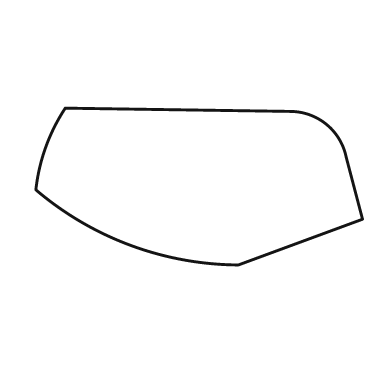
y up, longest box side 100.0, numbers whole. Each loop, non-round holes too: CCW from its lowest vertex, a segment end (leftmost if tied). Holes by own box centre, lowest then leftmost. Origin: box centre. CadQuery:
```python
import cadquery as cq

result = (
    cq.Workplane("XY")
    .moveTo(12.0, -24.0)
    .lineTo(50.0, -10.0)
    .lineTo(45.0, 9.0)
    .threePointArc((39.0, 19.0), (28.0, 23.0))
    .lineTo(-41.0, 24.0)
    .threePointArc((-47.0, 12.0), (-50.0, -1.0))
    .threePointArc((-21.0, -18.0), (12.0, -24.0))
    .close()
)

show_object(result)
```